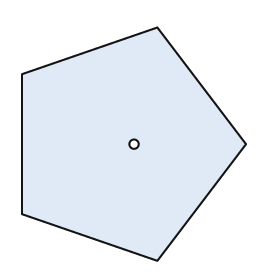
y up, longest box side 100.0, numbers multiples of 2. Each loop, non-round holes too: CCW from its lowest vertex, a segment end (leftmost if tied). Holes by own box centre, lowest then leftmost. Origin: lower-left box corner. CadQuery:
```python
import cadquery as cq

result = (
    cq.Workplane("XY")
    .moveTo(58.0, 0.0)
    .lineTo(96.0, 50.0)
    .lineTo(58.0, 100.0)
    .lineTo(0.0, 80.0)
    .lineTo(0.0, 20.0)
    .close()
    .moveTo(48.0, 50.0)
    .circle(2.0)
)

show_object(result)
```